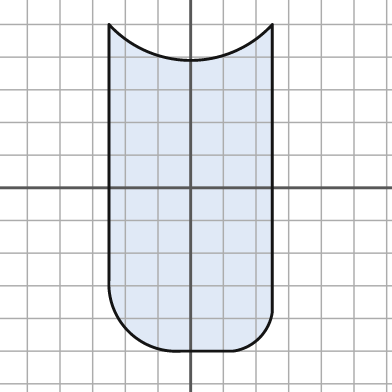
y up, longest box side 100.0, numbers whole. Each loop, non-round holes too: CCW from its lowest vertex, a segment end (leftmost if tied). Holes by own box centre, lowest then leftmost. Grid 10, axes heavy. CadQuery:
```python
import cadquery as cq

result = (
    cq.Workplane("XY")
    .moveTo(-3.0, -50.0)
    .lineTo(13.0, -50.0)
    .threePointArc((21.0, -46.0), (25.0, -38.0))
    .lineTo(25.0, 50.0)
    .threePointArc((0.0, 39.0), (-25.0, 50.0))
    .lineTo(-25.0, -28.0)
    .threePointArc((-19.0, -44.0), (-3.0, -50.0))
    .close()
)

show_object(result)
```